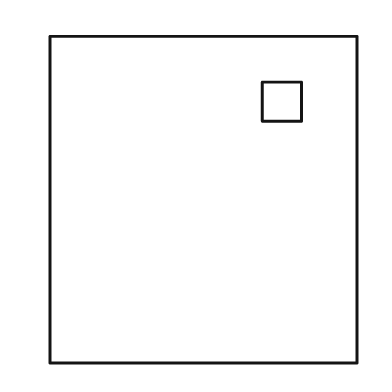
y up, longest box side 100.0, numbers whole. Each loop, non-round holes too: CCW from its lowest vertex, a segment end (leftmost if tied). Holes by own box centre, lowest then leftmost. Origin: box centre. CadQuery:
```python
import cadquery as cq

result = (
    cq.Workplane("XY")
    .moveTo(-47.0, -50.0)
    .lineTo(47.0, -50.0)
    .lineTo(47.0, 50.0)
    .lineTo(-47.0, 50.0)
    .close()
    .moveTo(18.0, 24.0)
    .lineTo(30.0, 24.0)
    .lineTo(30.0, 36.0)
    .lineTo(18.0, 36.0)
    .close()
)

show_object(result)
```